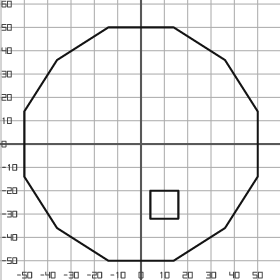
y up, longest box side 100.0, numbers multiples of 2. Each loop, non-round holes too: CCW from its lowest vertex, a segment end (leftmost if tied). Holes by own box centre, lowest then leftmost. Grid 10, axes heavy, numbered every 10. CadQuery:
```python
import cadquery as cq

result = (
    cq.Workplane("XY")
    .moveTo(-14.0, -50.0)
    .lineTo(14.0, -50.0)
    .lineTo(36.0, -36.0)
    .lineTo(50.0, -14.0)
    .lineTo(50.0, 14.0)
    .lineTo(36.0, 36.0)
    .lineTo(14.0, 50.0)
    .lineTo(-14.0, 50.0)
    .lineTo(-36.0, 36.0)
    .lineTo(-50.0, 14.0)
    .lineTo(-50.0, -14.0)
    .lineTo(-36.0, -36.0)
    .close()
    .moveTo(4.0, -32.0)
    .lineTo(16.0, -32.0)
    .lineTo(16.0, -20.0)
    .lineTo(4.0, -20.0)
    .close()
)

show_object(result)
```